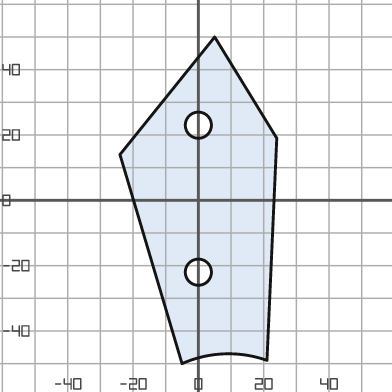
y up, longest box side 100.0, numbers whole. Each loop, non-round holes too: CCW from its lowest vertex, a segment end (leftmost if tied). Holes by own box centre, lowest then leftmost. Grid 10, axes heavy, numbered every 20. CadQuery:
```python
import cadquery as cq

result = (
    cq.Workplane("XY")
    .moveTo(-5.0, -50.0)
    .threePointArc((8.0, -47.0), (21.0, -49.0))
    .lineTo(24.0, 19.0)
    .lineTo(5.0, 50.0)
    .lineTo(-24.0, 14.0)
    .close()
    .moveTo(0.0, -22.0)
    .circle(4.0)
    .moveTo(0.0, 23.0)
    .circle(4.0)
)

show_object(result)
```